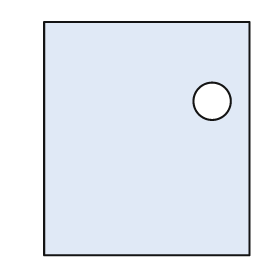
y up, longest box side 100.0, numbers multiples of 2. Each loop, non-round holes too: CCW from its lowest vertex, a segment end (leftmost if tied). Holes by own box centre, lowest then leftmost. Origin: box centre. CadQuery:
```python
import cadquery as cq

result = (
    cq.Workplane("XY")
    .moveTo(-44.0, -50.0)
    .lineTo(44.0, -50.0)
    .lineTo(44.0, 50.0)
    .lineTo(-44.0, 50.0)
    .close()
    .moveTo(28.0, 16.0)
    .circle(8.0)
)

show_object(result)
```